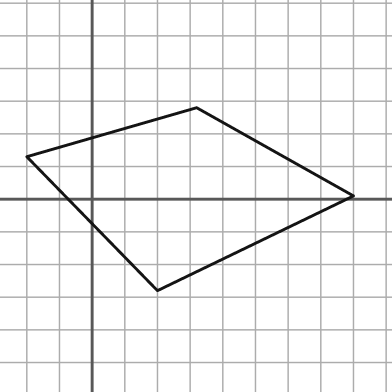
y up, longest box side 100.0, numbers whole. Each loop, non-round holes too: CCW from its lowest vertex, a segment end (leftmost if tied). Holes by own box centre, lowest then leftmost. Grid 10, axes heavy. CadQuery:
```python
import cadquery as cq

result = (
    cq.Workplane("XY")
    .moveTo(20.0, -28.0)
    .lineTo(80.0, 1.0)
    .lineTo(32.0, 28.0)
    .lineTo(-20.0, 13.0)
    .close()
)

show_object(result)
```